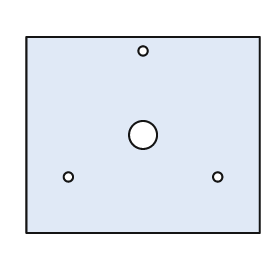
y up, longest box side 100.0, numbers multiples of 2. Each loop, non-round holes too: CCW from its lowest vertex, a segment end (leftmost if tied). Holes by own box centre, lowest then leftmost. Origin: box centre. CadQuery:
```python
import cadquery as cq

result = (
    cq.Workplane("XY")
    .moveTo(-50.0, -42.0)
    .lineTo(50.0, -42.0)
    .lineTo(50.0, 42.0)
    .lineTo(-50.0, 42.0)
    .close()
    .moveTo(-32.0, -18.0)
    .circle(2.0)
    .moveTo(32.0, -18.0)
    .circle(2.0)
    .moveTo(0.0, 0.0)
    .circle(6.0)
    .moveTo(0.0, 36.0)
    .circle(2.0)
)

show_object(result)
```